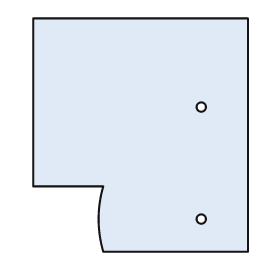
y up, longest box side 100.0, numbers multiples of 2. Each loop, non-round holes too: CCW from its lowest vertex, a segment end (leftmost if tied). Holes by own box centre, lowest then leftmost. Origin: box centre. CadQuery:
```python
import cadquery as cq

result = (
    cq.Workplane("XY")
    .moveTo(-16.0, -50.0)
    .lineTo(46.0, -50.0)
    .lineTo(46.0, 50.0)
    .lineTo(-46.0, 50.0)
    .lineTo(-46.0, -22.0)
    .lineTo(-16.0, -22.0)
    .threePointArc((-18.0, -36.0), (-16.0, -50.0))
    .close()
    .moveTo(26.0, -36.0)
    .circle(2.0)
    .moveTo(26.0, 12.0)
    .circle(2.0)
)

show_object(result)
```